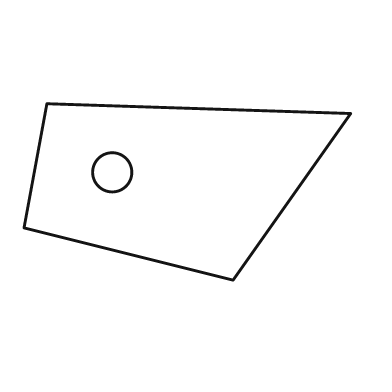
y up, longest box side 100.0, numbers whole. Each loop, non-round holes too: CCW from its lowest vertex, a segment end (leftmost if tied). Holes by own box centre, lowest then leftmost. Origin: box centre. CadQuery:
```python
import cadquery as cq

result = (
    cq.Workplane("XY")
    .moveTo(14.0, -27.0)
    .lineTo(50.0, 24.0)
    .lineTo(-43.0, 27.0)
    .lineTo(-50.0, -11.0)
    .close()
    .moveTo(-23.0, 6.0)
    .circle(6.0)
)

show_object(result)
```